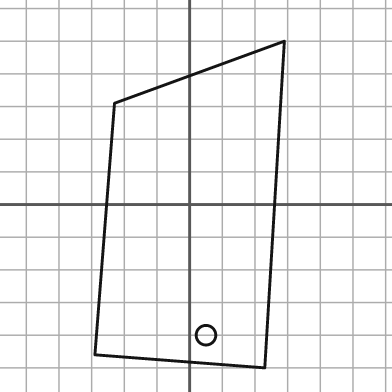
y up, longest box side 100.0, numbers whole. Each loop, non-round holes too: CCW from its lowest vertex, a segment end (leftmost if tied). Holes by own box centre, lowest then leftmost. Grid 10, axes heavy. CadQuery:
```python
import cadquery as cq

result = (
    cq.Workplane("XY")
    .moveTo(23.0, -50.0)
    .lineTo(29.0, 50.0)
    .lineTo(-23.0, 31.0)
    .lineTo(-29.0, -46.0)
    .close()
    .moveTo(5.0, -40.0)
    .circle(3.0)
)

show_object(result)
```